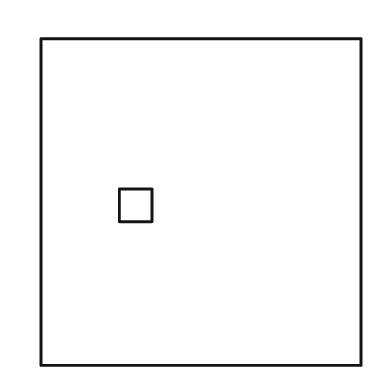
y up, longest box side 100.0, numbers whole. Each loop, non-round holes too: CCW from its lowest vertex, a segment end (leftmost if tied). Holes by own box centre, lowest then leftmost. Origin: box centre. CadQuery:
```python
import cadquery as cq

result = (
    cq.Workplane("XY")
    .moveTo(-49.0, -50.0)
    .lineTo(49.0, -50.0)
    .lineTo(49.0, 50.0)
    .lineTo(-49.0, 50.0)
    .close()
    .moveTo(-25.0, -6.0)
    .lineTo(-15.0, -6.0)
    .lineTo(-15.0, 4.0)
    .lineTo(-25.0, 4.0)
    .close()
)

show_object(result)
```